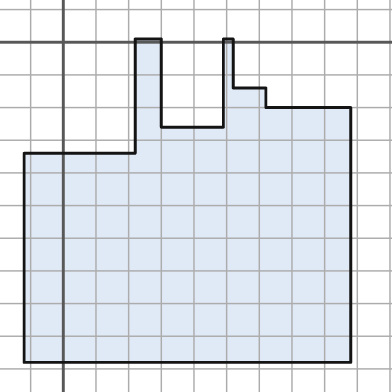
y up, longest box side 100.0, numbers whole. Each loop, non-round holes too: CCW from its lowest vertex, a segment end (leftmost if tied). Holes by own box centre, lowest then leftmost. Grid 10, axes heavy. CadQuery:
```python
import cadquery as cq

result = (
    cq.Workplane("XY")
    .moveTo(-12.0, -98.0)
    .lineTo(88.0, -98.0)
    .lineTo(88.0, -20.0)
    .lineTo(62.0, -20.0)
    .lineTo(62.0, -14.0)
    .lineTo(52.0, -14.0)
    .lineTo(52.0, 1.0)
    .lineTo(49.0, 1.0)
    .lineTo(49.0, -26.0)
    .lineTo(30.0, -26.0)
    .lineTo(30.0, 1.0)
    .lineTo(22.0, 1.0)
    .lineTo(22.0, -34.0)
    .lineTo(-12.0, -34.0)
    .close()
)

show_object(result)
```